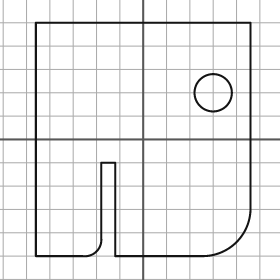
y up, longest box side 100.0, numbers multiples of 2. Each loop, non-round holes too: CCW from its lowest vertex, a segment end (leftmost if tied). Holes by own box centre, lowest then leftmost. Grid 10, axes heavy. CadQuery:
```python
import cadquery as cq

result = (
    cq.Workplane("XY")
    .moveTo(-46.0, -50.0)
    .lineTo(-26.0, -50.0)
    .threePointArc((-20.0, -48.0), (-18.0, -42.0))
    .lineTo(-18.0, -10.0)
    .lineTo(-12.0, -10.0)
    .lineTo(-12.0, -50.0)
    .lineTo(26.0, -50.0)
    .threePointArc((40.0, -44.0), (46.0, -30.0))
    .lineTo(46.0, 50.0)
    .lineTo(-46.0, 50.0)
    .close()
    .moveTo(30.0, 20.0)
    .circle(8.0)
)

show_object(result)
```